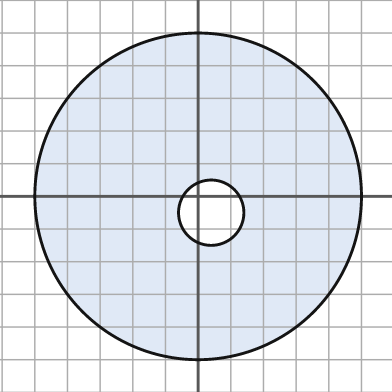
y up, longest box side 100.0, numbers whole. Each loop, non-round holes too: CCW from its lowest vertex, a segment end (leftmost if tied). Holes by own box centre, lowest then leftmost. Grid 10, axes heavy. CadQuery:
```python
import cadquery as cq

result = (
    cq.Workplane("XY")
    .moveTo(0.0, 0.0)
    .circle(50.0)
    .moveTo(4.0, -5.0)
    .circle(10.0)
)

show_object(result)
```